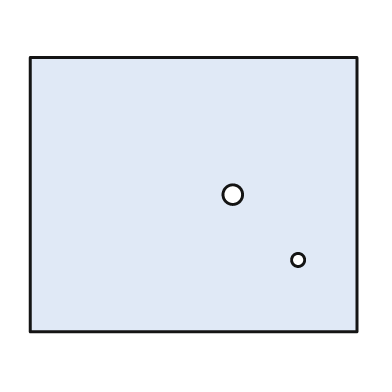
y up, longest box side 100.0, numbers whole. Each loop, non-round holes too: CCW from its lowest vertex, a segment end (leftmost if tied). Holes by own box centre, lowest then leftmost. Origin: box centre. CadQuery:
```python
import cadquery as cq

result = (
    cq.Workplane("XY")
    .moveTo(-50.0, -42.0)
    .lineTo(50.0, -42.0)
    .lineTo(50.0, 42.0)
    .lineTo(-50.0, 42.0)
    .close()
    .moveTo(32.0, -20.0)
    .circle(2.0)
    .moveTo(12.0, 0.0)
    .circle(3.0)
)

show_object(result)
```